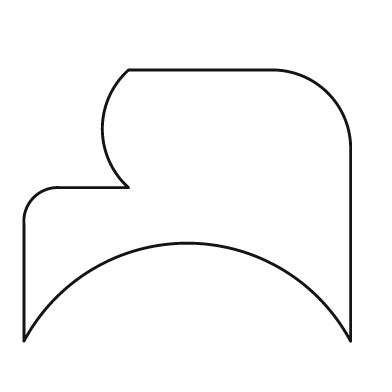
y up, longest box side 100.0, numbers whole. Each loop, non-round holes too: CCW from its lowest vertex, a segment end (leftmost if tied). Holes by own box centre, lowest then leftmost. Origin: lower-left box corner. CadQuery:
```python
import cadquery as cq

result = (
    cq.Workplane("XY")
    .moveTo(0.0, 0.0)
    .threePointArc((50.0, 30.0), (100.0, 0.0))
    .lineTo(100.0, 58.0)
    .threePointArc((93.0, 76.0), (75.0, 83.0))
    .lineTo(32.0, 83.0)
    .threePointArc((24.0, 65.0), (32.0, 47.0))
    .lineTo(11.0, 47.0)
    .threePointArc((3.0, 44.0), (0.0, 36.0))
    .close()
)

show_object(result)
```